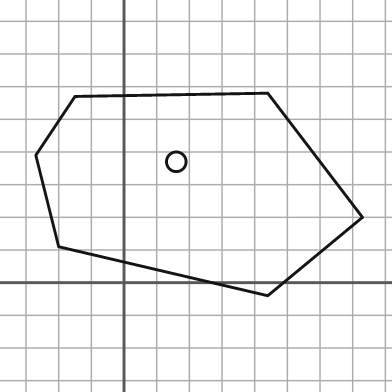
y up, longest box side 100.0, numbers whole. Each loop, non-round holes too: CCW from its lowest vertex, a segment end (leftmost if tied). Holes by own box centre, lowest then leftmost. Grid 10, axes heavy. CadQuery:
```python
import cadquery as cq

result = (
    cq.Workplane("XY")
    .moveTo(44.0, -4.0)
    .lineTo(73.0, 20.0)
    .lineTo(44.0, 58.0)
    .lineTo(-15.0, 57.0)
    .lineTo(-27.0, 39.0)
    .lineTo(-20.0, 11.0)
    .close()
    .moveTo(16.0, 37.0)
    .circle(3.0)
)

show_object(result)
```